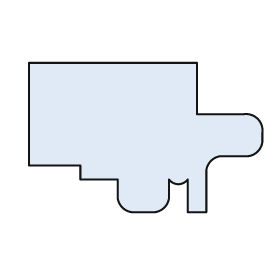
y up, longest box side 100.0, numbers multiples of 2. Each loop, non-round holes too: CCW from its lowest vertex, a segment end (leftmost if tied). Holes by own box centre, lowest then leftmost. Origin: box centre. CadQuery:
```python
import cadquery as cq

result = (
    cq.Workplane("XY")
    .moveTo(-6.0, -32.0)
    .lineTo(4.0, -32.0)
    .threePointArc((8.0, -30.0), (10.0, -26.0))
    .lineTo(10.0, -18.0)
    .threePointArc((14.0, -20.0), (18.0, -18.0))
    .lineTo(18.0, -32.0)
    .lineTo(26.0, -32.0)
    .lineTo(26.0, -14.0)
    .threePointArc((28.0, -10.0), (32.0, -8.0))
    .lineTo(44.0, -8.0)
    .threePointArc((48.0, -6.0), (50.0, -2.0))
    .lineTo(50.0, 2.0)
    .threePointArc((48.0, 8.0), (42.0, 10.0))
    .lineTo(22.0, 10.0)
    .lineTo(22.0, 32.0)
    .lineTo(-50.0, 32.0)
    .lineTo(-50.0, -12.0)
    .lineTo(-28.0, -12.0)
    .lineTo(-28.0, -18.0)
    .lineTo(-12.0, -18.0)
    .lineTo(-12.0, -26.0)
    .threePointArc((-10.0, -30.0), (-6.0, -32.0))
    .close()
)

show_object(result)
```